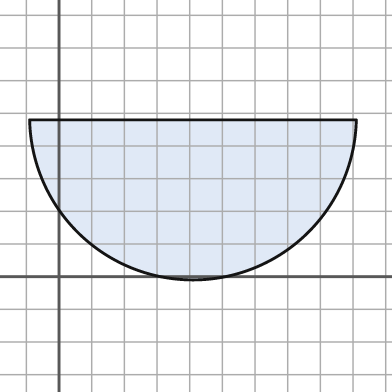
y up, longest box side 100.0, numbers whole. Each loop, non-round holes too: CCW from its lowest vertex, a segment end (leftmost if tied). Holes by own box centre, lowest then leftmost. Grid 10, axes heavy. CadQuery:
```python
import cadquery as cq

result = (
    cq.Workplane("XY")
    .moveTo(-9.0, 48.0)
    .threePointArc((41.0, -1.0), (91.0, 48.0))
    .close()
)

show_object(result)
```